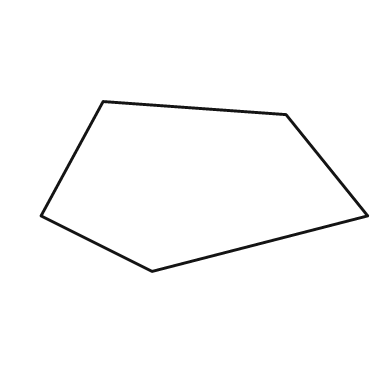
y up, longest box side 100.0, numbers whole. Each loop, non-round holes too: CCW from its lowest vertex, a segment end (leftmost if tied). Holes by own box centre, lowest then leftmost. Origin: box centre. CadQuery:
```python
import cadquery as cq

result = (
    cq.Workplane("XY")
    .moveTo(-16.0, -26.0)
    .lineTo(50.0, -9.0)
    .lineTo(25.0, 22.0)
    .lineTo(-31.0, 26.0)
    .lineTo(-50.0, -9.0)
    .close()
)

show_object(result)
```